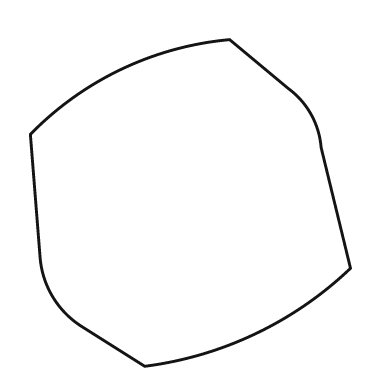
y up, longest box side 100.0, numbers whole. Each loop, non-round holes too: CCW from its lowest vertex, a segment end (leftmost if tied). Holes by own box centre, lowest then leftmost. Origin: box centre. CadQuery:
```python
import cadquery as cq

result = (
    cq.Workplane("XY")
    .moveTo(-14.0, -50.0)
    .threePointArc((20.0, -40.0), (49.0, -20.0))
    .lineTo(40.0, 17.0)
    .threePointArc((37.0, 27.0), (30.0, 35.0))
    .lineTo(12.0, 50.0)
    .threePointArc((-21.0, 41.0), (-49.0, 21.0))
    .lineTo(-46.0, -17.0)
    .threePointArc((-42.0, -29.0), (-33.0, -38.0))
    .close()
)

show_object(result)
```